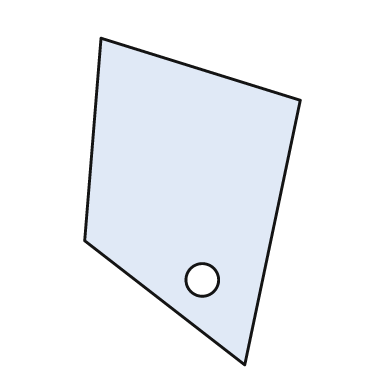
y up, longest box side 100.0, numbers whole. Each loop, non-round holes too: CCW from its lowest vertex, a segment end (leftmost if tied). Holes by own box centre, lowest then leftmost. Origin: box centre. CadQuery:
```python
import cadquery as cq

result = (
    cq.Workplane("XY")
    .moveTo(16.0, -50.0)
    .lineTo(33.0, 31.0)
    .lineTo(-28.0, 50.0)
    .lineTo(-33.0, -12.0)
    .close()
    .moveTo(3.0, -24.0)
    .circle(5.0)
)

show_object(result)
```